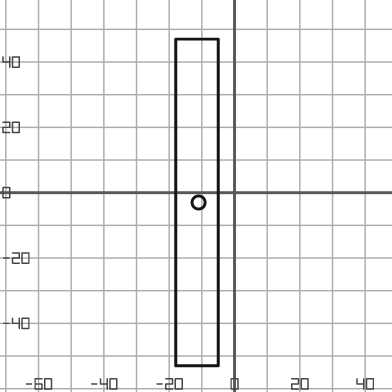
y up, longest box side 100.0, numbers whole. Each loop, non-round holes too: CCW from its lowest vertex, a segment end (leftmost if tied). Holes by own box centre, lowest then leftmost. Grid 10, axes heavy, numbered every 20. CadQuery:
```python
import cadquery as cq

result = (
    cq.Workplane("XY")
    .moveTo(-18.0, -53.0)
    .lineTo(-5.0, -53.0)
    .lineTo(-5.0, 47.0)
    .lineTo(-18.0, 47.0)
    .close()
    .moveTo(-11.0, -3.0)
    .circle(2.0)
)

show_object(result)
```